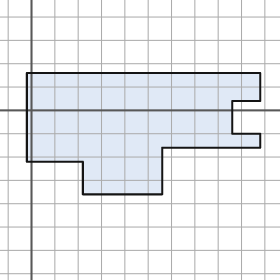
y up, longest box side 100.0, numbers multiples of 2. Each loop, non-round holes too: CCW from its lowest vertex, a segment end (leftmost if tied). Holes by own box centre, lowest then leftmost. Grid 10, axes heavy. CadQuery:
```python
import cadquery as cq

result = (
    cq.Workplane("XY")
    .moveTo(22.0, -36.0)
    .lineTo(56.0, -36.0)
    .lineTo(56.0, -16.0)
    .lineTo(98.0, -16.0)
    .lineTo(98.0, -10.0)
    .lineTo(86.0, -10.0)
    .lineTo(86.0, 4.0)
    .lineTo(98.0, 4.0)
    .lineTo(98.0, 16.0)
    .lineTo(-2.0, 16.0)
    .lineTo(-2.0, -22.0)
    .lineTo(22.0, -22.0)
    .close()
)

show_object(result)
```